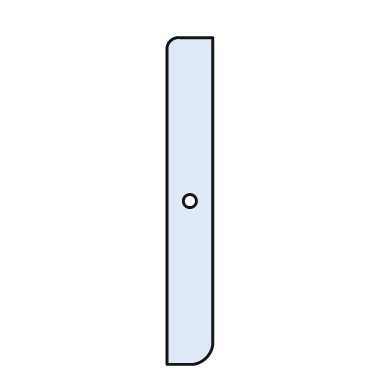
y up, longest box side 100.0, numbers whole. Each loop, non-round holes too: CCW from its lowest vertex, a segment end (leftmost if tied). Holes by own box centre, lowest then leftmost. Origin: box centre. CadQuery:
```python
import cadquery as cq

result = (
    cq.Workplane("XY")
    .moveTo(-7.0, -50.0)
    .lineTo(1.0, -50.0)
    .threePointArc((5.0, -48.0), (7.0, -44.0))
    .lineTo(7.0, 50.0)
    .lineTo(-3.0, 50.0)
    .threePointArc((-6.0, 49.0), (-7.0, 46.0))
    .close()
    .moveTo(0.0, 0.0)
    .circle(2.0)
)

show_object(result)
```